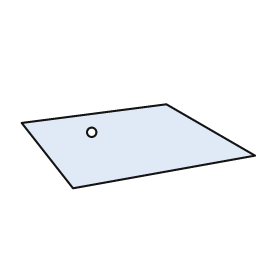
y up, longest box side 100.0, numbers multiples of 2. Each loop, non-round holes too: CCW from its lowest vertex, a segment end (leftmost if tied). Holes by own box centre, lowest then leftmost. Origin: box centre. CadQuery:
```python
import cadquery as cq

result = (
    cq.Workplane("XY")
    .moveTo(-28.0, -18.0)
    .lineTo(50.0, -4.0)
    .lineTo(12.0, 18.0)
    .lineTo(-50.0, 10.0)
    .close()
    .moveTo(-20.0, 6.0)
    .circle(2.0)
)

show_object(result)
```